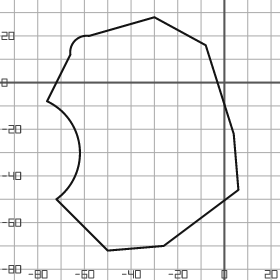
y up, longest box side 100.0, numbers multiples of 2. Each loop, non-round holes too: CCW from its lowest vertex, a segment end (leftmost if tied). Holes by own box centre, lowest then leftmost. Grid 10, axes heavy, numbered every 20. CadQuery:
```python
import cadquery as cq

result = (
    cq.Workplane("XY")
    .moveTo(-50.0, -72.0)
    .lineTo(-26.0, -70.0)
    .lineTo(6.0, -46.0)
    .lineTo(4.0, -22.0)
    .lineTo(-8.0, 16.0)
    .lineTo(-30.0, 28.0)
    .lineTo(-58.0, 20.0)
    .threePointArc((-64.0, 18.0), (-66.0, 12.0))
    .lineTo(-76.0, -8.0)
    .threePointArc((-62.0, -28.0), (-72.0, -50.0))
    .close()
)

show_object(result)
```